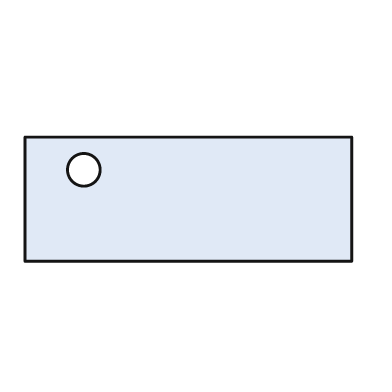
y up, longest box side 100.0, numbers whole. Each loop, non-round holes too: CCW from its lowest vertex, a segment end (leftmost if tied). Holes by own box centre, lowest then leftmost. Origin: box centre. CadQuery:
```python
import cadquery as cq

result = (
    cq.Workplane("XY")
    .moveTo(-50.0, -19.0)
    .lineTo(50.0, -19.0)
    .lineTo(50.0, 19.0)
    .lineTo(-50.0, 19.0)
    .close()
    .moveTo(-32.0, 9.0)
    .circle(5.0)
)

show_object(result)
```